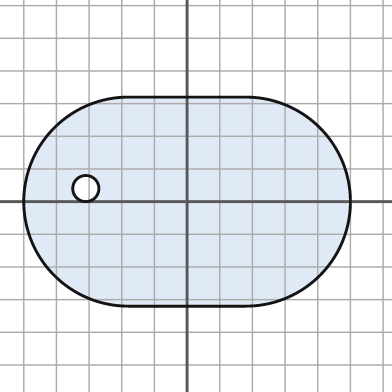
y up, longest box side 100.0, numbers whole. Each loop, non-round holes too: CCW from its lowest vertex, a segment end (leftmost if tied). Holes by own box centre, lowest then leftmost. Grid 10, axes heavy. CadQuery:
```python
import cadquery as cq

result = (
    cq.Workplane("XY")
    .moveTo(-18.0, -32.0)
    .lineTo(18.0, -32.0)
    .threePointArc((50.0, 0.0), (18.0, 32.0))
    .lineTo(-18.0, 32.0)
    .threePointArc((-50.0, 0.0), (-18.0, -32.0))
    .close()
    .moveTo(-31.0, 4.0)
    .circle(4.0)
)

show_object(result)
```